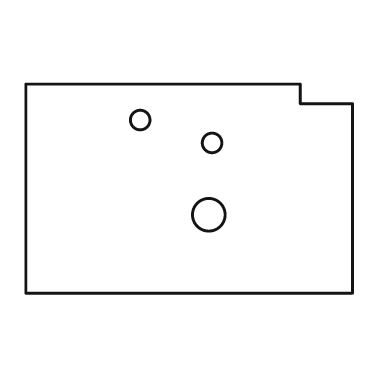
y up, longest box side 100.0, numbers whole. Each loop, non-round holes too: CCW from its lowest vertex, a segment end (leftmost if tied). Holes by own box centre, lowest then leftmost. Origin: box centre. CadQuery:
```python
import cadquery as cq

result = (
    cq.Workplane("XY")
    .moveTo(-50.0, -32.0)
    .lineTo(50.0, -32.0)
    .lineTo(50.0, 26.0)
    .lineTo(34.0, 26.0)
    .lineTo(34.0, 32.0)
    .lineTo(-50.0, 32.0)
    .close()
    .moveTo(6.0, -8.0)
    .circle(5.0)
    .moveTo(7.0, 14.0)
    .circle(3.0)
    .moveTo(-15.0, 21.0)
    .circle(3.0)
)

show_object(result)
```